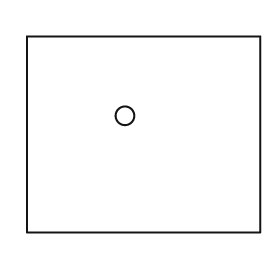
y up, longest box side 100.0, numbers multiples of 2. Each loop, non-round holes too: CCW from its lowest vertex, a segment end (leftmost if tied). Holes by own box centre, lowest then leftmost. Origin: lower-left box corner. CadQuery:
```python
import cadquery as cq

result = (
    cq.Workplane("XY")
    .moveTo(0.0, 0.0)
    .lineTo(100.0, 0.0)
    .lineTo(100.0, 84.0)
    .lineTo(0.0, 84.0)
    .close()
    .moveTo(42.0, 50.0)
    .circle(4.0)
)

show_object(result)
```